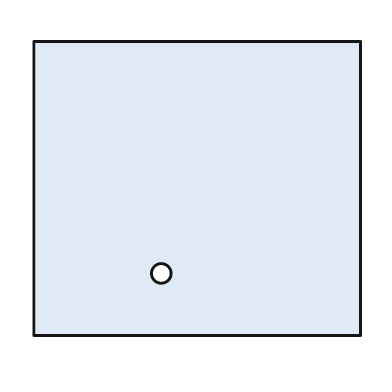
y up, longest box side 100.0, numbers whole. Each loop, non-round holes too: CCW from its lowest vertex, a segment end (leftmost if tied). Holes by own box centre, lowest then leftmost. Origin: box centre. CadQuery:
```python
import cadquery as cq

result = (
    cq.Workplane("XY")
    .moveTo(-50.0, -45.0)
    .lineTo(50.0, -45.0)
    .lineTo(50.0, 45.0)
    .lineTo(-50.0, 45.0)
    .close()
    .moveTo(-11.0, -26.0)
    .circle(3.0)
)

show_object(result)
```